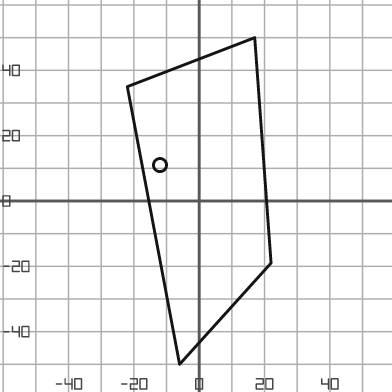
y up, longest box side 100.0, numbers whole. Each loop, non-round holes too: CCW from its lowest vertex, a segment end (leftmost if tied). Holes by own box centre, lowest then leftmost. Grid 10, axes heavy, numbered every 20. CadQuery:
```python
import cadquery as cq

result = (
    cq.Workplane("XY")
    .moveTo(-6.0, -50.0)
    .lineTo(22.0, -19.0)
    .lineTo(17.0, 50.0)
    .lineTo(-22.0, 35.0)
    .close()
    .moveTo(-12.0, 11.0)
    .circle(2.0)
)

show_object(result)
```